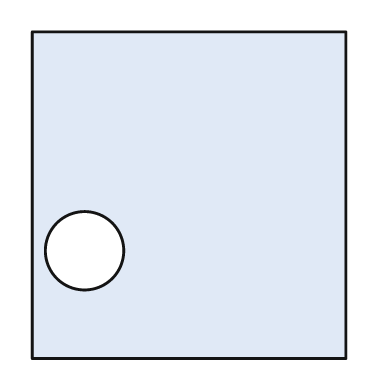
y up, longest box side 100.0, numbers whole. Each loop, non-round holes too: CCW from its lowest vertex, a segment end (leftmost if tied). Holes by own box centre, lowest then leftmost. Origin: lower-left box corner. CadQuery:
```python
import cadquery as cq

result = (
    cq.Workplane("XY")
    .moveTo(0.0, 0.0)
    .lineTo(96.0, 0.0)
    .lineTo(96.0, 100.0)
    .lineTo(0.0, 100.0)
    .close()
    .moveTo(16.0, 33.0)
    .circle(12.0)
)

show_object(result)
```